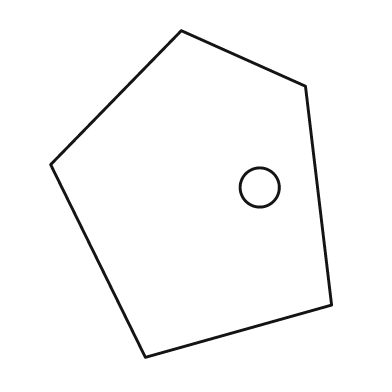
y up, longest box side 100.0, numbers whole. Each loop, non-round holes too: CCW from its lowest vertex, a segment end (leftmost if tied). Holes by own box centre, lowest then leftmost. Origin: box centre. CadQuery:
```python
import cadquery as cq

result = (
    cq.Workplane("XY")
    .moveTo(-14.0, -50.0)
    .lineTo(43.0, -34.0)
    .lineTo(35.0, 33.0)
    .lineTo(-3.0, 50.0)
    .lineTo(-43.0, 9.0)
    .close()
    .moveTo(21.0, 2.0)
    .circle(6.0)
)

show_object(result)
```